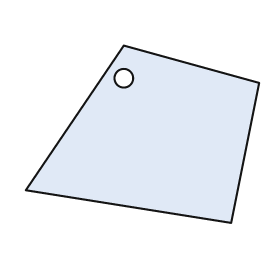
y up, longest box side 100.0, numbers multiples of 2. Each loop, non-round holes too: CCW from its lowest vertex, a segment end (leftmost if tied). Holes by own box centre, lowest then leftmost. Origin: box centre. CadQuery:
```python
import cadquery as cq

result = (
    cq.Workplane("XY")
    .moveTo(38.0, -38.0)
    .lineTo(50.0, 22.0)
    .lineTo(-8.0, 38.0)
    .lineTo(-50.0, -24.0)
    .close()
    .moveTo(-8.0, 24.0)
    .circle(4.0)
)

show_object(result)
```